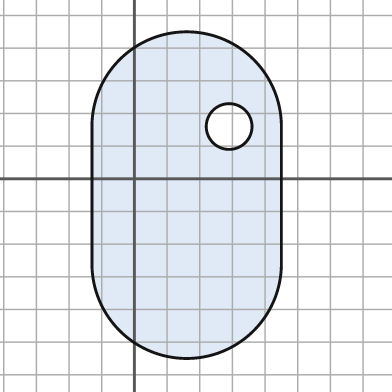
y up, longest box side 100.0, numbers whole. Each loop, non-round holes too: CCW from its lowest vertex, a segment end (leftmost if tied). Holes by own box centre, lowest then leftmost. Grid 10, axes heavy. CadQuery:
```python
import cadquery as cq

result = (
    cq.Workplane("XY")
    .moveTo(-13.0, -26.0)
    .threePointArc((16.0, -55.0), (45.0, -26.0))
    .lineTo(45.0, 16.0)
    .threePointArc((16.0, 45.0), (-13.0, 16.0))
    .close()
    .moveTo(29.0, 16.0)
    .circle(7.0)
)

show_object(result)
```